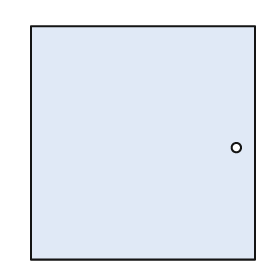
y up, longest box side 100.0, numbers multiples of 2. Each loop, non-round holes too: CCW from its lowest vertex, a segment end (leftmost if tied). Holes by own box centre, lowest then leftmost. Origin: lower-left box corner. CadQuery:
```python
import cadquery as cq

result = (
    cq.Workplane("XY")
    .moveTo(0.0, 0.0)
    .lineTo(96.0, 0.0)
    .lineTo(96.0, 100.0)
    .lineTo(0.0, 100.0)
    .close()
    .moveTo(88.0, 48.0)
    .circle(2.0)
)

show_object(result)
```